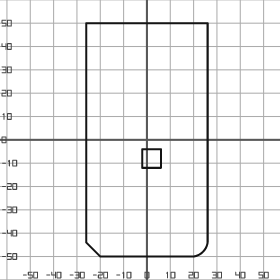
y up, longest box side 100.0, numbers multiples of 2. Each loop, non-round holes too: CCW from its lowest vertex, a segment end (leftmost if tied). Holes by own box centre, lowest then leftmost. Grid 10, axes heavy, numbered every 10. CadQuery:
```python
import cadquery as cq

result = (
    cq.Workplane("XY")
    .moveTo(-20.0, -50.0)
    .lineTo(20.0, -50.0)
    .threePointArc((24.0, -48.0), (26.0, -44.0))
    .lineTo(26.0, 50.0)
    .lineTo(-26.0, 50.0)
    .lineTo(-26.0, -44.0)
    .close()
    .moveTo(-2.0, -12.0)
    .lineTo(6.0, -12.0)
    .lineTo(6.0, -4.0)
    .lineTo(-2.0, -4.0)
    .close()
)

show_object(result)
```